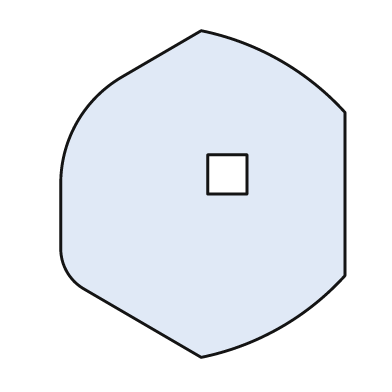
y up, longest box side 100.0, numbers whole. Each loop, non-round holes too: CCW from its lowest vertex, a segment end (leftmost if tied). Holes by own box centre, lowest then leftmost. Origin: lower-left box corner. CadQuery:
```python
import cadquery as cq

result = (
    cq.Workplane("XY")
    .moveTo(43.0, 0.0)
    .threePointArc((67.0, 9.0), (87.0, 25.0))
    .lineTo(87.0, 75.0)
    .threePointArc((67.0, 91.0), (43.0, 100.0))
    .lineTo(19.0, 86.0)
    .threePointArc((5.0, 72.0), (0.0, 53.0))
    .lineTo(0.0, 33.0)
    .threePointArc((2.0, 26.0), (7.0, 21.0))
    .close()
    .moveTo(45.0, 50.0)
    .lineTo(57.0, 50.0)
    .lineTo(57.0, 62.0)
    .lineTo(45.0, 62.0)
    .close()
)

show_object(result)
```